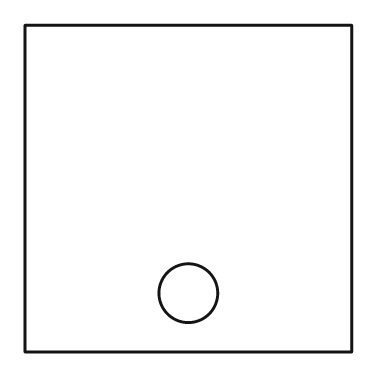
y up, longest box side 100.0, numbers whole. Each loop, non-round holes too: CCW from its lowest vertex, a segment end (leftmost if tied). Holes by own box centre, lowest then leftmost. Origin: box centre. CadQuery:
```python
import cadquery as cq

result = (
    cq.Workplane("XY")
    .moveTo(-50.0, -50.0)
    .lineTo(50.0, -50.0)
    .lineTo(50.0, 50.0)
    .lineTo(-50.0, 50.0)
    .close()
    .moveTo(0.0, -32.0)
    .circle(9.0)
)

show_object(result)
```